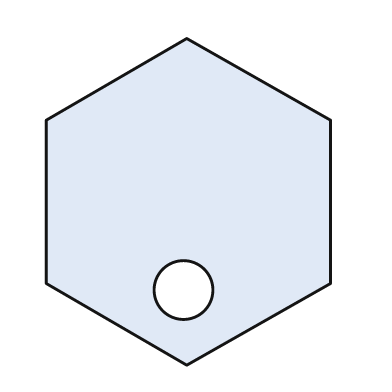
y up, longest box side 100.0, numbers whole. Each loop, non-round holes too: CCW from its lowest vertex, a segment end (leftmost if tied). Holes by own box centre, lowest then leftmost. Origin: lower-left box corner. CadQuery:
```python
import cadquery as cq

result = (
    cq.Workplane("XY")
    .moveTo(43.0, 0.0)
    .lineTo(87.0, 25.0)
    .lineTo(87.0, 75.0)
    .lineTo(43.0, 100.0)
    .lineTo(0.0, 75.0)
    .lineTo(0.0, 25.0)
    .close()
    .moveTo(42.0, 23.0)
    .circle(9.0)
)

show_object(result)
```